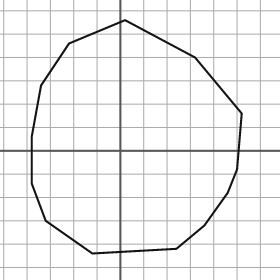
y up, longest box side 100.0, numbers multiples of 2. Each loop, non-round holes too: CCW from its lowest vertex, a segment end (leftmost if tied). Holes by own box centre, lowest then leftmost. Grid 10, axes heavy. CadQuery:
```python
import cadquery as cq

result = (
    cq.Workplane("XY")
    .moveTo(-12.0, -44.0)
    .lineTo(24.0, -42.0)
    .lineTo(36.0, -32.0)
    .lineTo(46.0, -18.0)
    .lineTo(50.0, -8.0)
    .lineTo(52.0, 16.0)
    .lineTo(32.0, 40.0)
    .lineTo(2.0, 56.0)
    .lineTo(-22.0, 46.0)
    .lineTo(-34.0, 28.0)
    .lineTo(-38.0, 6.0)
    .lineTo(-38.0, -14.0)
    .lineTo(-32.0, -30.0)
    .close()
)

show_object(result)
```